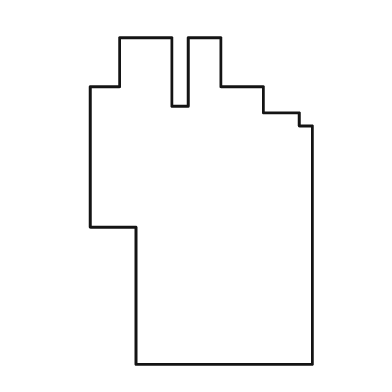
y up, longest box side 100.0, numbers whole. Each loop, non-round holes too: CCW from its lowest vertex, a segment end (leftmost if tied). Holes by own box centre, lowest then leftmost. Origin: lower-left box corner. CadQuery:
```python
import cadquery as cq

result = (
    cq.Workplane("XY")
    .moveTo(14.0, 0.0)
    .lineTo(68.0, 0.0)
    .lineTo(68.0, 73.0)
    .lineTo(64.0, 73.0)
    .lineTo(64.0, 77.0)
    .lineTo(53.0, 77.0)
    .lineTo(53.0, 85.0)
    .lineTo(40.0, 85.0)
    .lineTo(40.0, 100.0)
    .lineTo(30.0, 100.0)
    .lineTo(30.0, 79.0)
    .lineTo(25.0, 79.0)
    .lineTo(25.0, 100.0)
    .lineTo(9.0, 100.0)
    .lineTo(9.0, 85.0)
    .lineTo(0.0, 85.0)
    .lineTo(0.0, 42.0)
    .lineTo(14.0, 42.0)
    .close()
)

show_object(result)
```